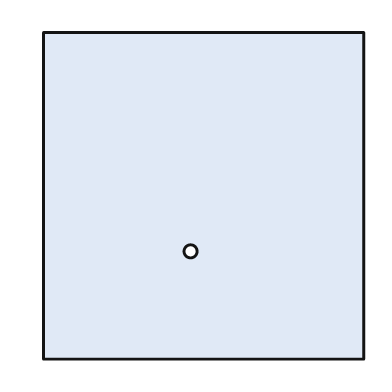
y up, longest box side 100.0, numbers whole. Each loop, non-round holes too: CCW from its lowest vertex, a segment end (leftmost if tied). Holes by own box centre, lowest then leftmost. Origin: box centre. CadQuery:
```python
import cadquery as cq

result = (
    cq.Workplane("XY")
    .moveTo(-49.0, -50.0)
    .lineTo(49.0, -50.0)
    .lineTo(49.0, 50.0)
    .lineTo(-49.0, 50.0)
    .close()
    .moveTo(-4.0, -17.0)
    .circle(2.0)
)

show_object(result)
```